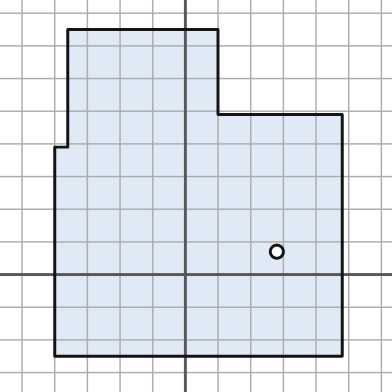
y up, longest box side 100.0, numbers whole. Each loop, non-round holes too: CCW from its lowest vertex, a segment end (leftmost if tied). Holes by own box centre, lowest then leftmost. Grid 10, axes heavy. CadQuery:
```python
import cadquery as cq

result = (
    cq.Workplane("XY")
    .moveTo(-40.0, -25.0)
    .lineTo(48.0, -25.0)
    .lineTo(48.0, 49.0)
    .lineTo(10.0, 49.0)
    .lineTo(10.0, 75.0)
    .lineTo(-36.0, 75.0)
    .lineTo(-36.0, 39.0)
    .lineTo(-40.0, 39.0)
    .close()
    .moveTo(28.0, 7.0)
    .circle(2.0)
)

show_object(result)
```